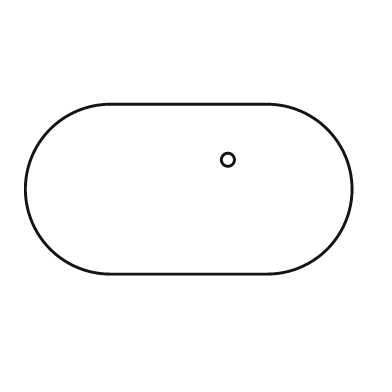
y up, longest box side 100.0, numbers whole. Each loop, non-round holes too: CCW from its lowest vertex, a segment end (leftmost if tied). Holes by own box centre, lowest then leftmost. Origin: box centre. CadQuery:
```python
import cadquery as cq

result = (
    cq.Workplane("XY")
    .moveTo(-24.0, -26.0)
    .lineTo(24.0, -26.0)
    .threePointArc((50.0, 0.0), (24.0, 26.0))
    .lineTo(-24.0, 26.0)
    .threePointArc((-50.0, 0.0), (-24.0, -26.0))
    .close()
    .moveTo(12.0, 9.0)
    .circle(2.0)
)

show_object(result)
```